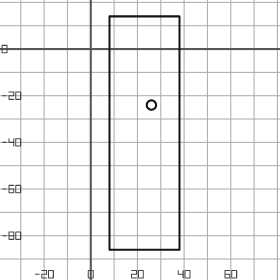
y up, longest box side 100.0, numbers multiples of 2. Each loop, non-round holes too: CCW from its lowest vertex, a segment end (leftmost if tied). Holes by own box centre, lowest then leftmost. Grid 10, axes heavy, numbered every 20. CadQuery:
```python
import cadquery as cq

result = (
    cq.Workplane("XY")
    .moveTo(8.0, -86.0)
    .lineTo(38.0, -86.0)
    .lineTo(38.0, 14.0)
    .lineTo(8.0, 14.0)
    .close()
    .moveTo(26.0, -24.0)
    .circle(2.0)
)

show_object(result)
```